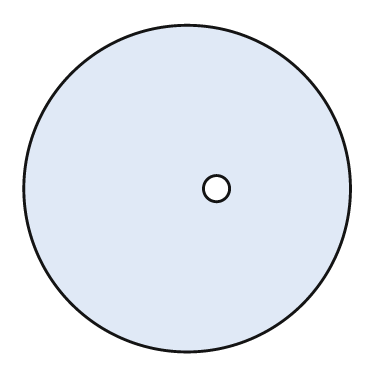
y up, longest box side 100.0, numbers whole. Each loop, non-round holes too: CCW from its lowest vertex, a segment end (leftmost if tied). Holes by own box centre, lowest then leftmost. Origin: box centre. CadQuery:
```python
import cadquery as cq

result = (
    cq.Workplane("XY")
    .moveTo(0.0, 0.0)
    .circle(50.0)
    .moveTo(9.0, 0.0)
    .circle(4.0)
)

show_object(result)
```